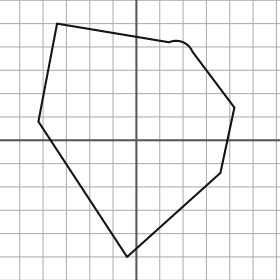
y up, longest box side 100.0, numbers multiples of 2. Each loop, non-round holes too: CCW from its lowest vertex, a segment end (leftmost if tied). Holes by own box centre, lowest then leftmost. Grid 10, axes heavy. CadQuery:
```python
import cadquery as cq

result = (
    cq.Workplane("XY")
    .moveTo(-4.0, -50.0)
    .lineTo(36.0, -14.0)
    .lineTo(42.0, 14.0)
    .lineTo(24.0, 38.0)
    .threePointArc((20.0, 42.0), (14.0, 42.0))
    .lineTo(-34.0, 50.0)
    .lineTo(-42.0, 8.0)
    .close()
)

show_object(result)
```